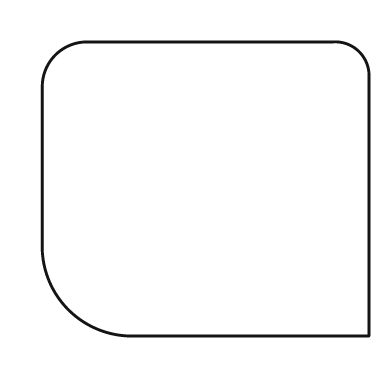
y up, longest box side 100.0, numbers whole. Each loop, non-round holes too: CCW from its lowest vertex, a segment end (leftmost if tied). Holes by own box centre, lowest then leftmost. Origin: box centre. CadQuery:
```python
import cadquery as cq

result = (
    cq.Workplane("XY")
    .moveTo(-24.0, -45.0)
    .lineTo(50.0, -45.0)
    .lineTo(50.0, 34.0)
    .threePointArc((47.0, 42.0), (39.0, 45.0))
    .lineTo(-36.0, 45.0)
    .threePointArc((-46.0, 41.0), (-50.0, 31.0))
    .lineTo(-50.0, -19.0)
    .threePointArc((-42.0, -37.0), (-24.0, -45.0))
    .close()
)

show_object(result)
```